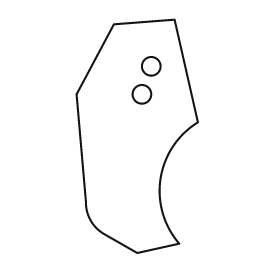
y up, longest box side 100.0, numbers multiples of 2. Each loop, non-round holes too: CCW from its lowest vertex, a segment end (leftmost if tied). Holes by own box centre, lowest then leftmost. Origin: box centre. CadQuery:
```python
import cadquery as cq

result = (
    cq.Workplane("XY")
    .moveTo(0.0, -50.0)
    .lineTo(18.0, -46.0)
    .threePointArc((10.0, -18.0), (26.0, 6.0))
    .lineTo(16.0, 50.0)
    .lineTo(-10.0, 48.0)
    .lineTo(-26.0, 18.0)
    .lineTo(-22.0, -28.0)
    .threePointArc((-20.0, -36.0), (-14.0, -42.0))
    .close()
    .moveTo(2.0, 18.0)
    .circle(4.0)
    .moveTo(6.0, 30.0)
    .circle(4.0)
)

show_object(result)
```